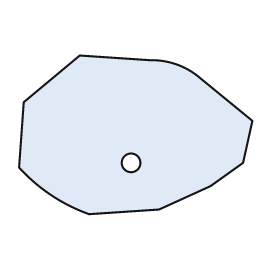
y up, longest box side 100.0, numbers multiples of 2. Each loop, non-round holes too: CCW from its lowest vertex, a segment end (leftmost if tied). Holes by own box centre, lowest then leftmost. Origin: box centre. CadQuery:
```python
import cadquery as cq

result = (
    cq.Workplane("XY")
    .moveTo(-20.0, -34.0)
    .lineTo(10.0, -32.0)
    .lineTo(32.0, -22.0)
    .lineTo(46.0, -12.0)
    .lineTo(50.0, 6.0)
    .lineTo(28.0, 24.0)
    .threePointArc((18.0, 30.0), (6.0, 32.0))
    .lineTo(-24.0, 34.0)
    .lineTo(-48.0, 14.0)
    .lineTo(-50.0, -14.0)
    .threePointArc((-36.0, -26.0), (-20.0, -34.0))
    .close()
    .moveTo(-2.0, -12.0)
    .circle(4.0)
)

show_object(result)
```